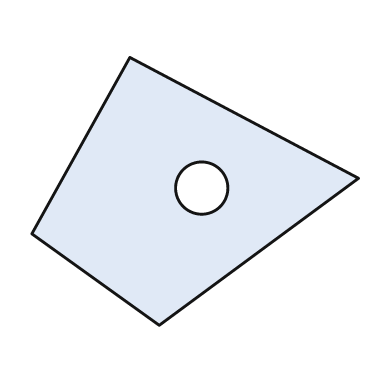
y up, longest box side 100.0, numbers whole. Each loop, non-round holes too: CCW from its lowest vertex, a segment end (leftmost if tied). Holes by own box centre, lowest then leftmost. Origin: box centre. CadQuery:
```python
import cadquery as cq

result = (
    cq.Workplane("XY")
    .moveTo(-11.0, -41.0)
    .lineTo(50.0, 4.0)
    .lineTo(-20.0, 41.0)
    .lineTo(-50.0, -13.0)
    .close()
    .moveTo(2.0, 1.0)
    .circle(8.0)
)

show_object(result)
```